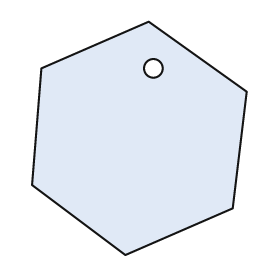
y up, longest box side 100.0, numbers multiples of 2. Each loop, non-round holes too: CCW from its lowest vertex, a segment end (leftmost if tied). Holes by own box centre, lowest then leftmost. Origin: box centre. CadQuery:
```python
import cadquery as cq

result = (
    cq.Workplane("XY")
    .moveTo(-6.0, -50.0)
    .lineTo(40.0, -30.0)
    .lineTo(46.0, 20.0)
    .lineTo(4.0, 50.0)
    .lineTo(-42.0, 30.0)
    .lineTo(-46.0, -20.0)
    .close()
    .moveTo(6.0, 30.0)
    .circle(4.0)
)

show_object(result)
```